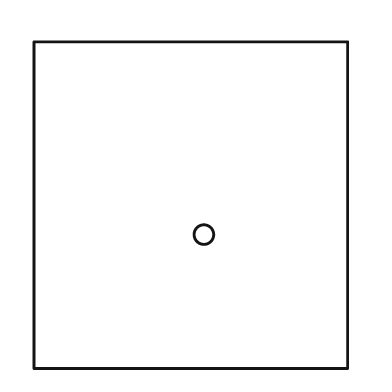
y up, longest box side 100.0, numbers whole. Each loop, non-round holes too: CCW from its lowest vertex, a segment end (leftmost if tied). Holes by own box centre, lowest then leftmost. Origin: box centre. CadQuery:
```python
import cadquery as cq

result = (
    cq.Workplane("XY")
    .moveTo(-48.0, -50.0)
    .lineTo(48.0, -50.0)
    .lineTo(48.0, 50.0)
    .lineTo(-48.0, 50.0)
    .close()
    .moveTo(4.0, -9.0)
    .circle(3.0)
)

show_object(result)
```